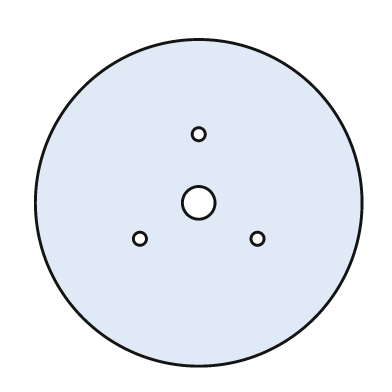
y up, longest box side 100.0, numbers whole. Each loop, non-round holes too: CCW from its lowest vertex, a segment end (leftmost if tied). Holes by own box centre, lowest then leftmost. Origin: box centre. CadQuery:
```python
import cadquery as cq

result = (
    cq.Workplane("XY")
    .moveTo(0.0, 0.0)
    .circle(50.0)
    .moveTo(-18.0, -11.0)
    .circle(2.0)
    .moveTo(18.0, -11.0)
    .circle(2.0)
    .moveTo(0.0, 0.0)
    .circle(5.0)
    .moveTo(0.0, 21.0)
    .circle(2.0)
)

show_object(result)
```